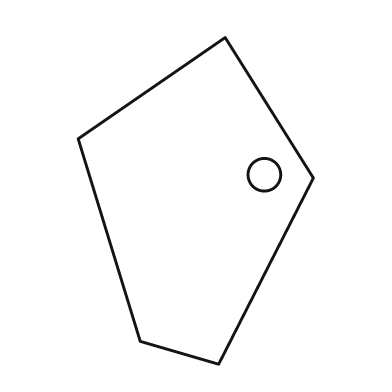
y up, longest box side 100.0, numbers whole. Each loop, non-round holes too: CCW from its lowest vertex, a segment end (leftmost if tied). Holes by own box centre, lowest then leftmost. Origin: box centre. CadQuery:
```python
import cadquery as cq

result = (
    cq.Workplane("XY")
    .moveTo(7.0, -50.0)
    .lineTo(36.0, 7.0)
    .lineTo(9.0, 50.0)
    .lineTo(-36.0, 19.0)
    .lineTo(-17.0, -43.0)
    .close()
    .moveTo(21.0, 8.0)
    .circle(5.0)
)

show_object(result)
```